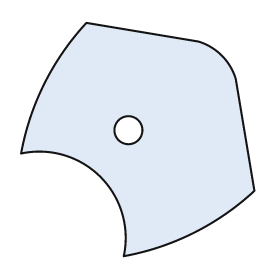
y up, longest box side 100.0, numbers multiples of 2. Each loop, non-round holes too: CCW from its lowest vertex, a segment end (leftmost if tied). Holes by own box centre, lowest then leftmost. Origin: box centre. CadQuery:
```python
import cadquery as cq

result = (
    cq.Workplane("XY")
    .moveTo(-6.0, -50.0)
    .threePointArc((24.0, -40.0), (50.0, -22.0))
    .lineTo(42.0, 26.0)
    .threePointArc((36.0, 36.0), (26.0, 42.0))
    .lineTo(-22.0, 50.0)
    .threePointArc((-40.0, 24.0), (-50.0, -6.0))
    .threePointArc((-16.0, -16.0), (-6.0, -50.0))
    .close()
    .moveTo(-4.0, 4.0)
    .circle(6.0)
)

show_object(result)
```